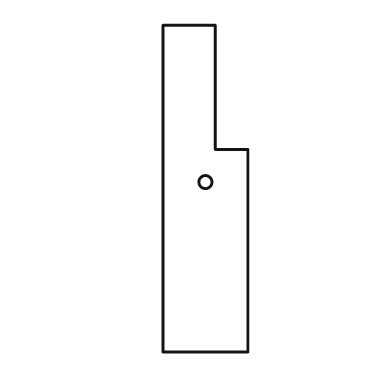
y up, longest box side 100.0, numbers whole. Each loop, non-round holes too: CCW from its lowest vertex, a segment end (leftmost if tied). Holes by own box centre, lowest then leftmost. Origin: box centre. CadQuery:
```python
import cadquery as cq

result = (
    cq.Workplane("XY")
    .moveTo(-13.0, -50.0)
    .lineTo(13.0, -50.0)
    .lineTo(13.0, 12.0)
    .lineTo(3.0, 12.0)
    .lineTo(3.0, 50.0)
    .lineTo(-13.0, 50.0)
    .close()
    .moveTo(0.0, 2.0)
    .circle(2.0)
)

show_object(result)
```